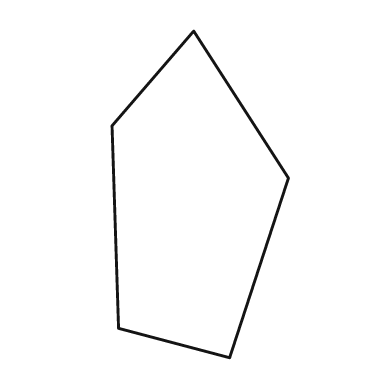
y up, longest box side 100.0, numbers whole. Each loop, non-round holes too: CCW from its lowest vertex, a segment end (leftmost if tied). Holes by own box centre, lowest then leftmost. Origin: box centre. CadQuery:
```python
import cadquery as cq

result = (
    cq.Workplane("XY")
    .moveTo(9.0, -50.0)
    .lineTo(27.0, 5.0)
    .lineTo(-2.0, 50.0)
    .lineTo(-27.0, 21.0)
    .lineTo(-25.0, -41.0)
    .close()
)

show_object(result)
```